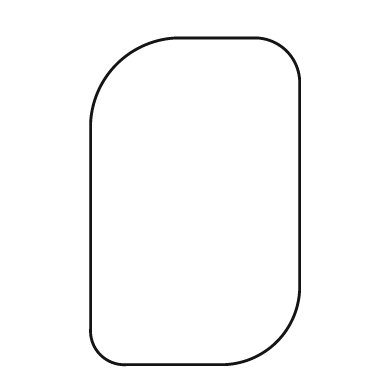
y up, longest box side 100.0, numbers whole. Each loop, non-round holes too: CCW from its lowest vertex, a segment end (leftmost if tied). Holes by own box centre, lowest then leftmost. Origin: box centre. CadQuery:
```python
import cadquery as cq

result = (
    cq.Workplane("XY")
    .moveTo(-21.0, -50.0)
    .lineTo(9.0, -50.0)
    .threePointArc((25.0, -43.0), (32.0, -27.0))
    .lineTo(32.0, 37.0)
    .threePointArc((28.0, 46.0), (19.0, 50.0))
    .lineTo(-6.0, 50.0)
    .threePointArc((-24.0, 42.0), (-32.0, 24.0))
    .lineTo(-32.0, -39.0)
    .threePointArc((-29.0, -47.0), (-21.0, -50.0))
    .close()
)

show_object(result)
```